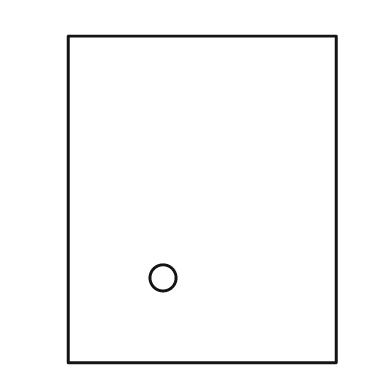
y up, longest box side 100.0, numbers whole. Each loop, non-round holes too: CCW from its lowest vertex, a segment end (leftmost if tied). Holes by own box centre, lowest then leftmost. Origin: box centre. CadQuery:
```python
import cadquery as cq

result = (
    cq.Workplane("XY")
    .moveTo(-41.0, -50.0)
    .lineTo(41.0, -50.0)
    .lineTo(41.0, 50.0)
    .lineTo(-41.0, 50.0)
    .close()
    .moveTo(-12.0, -24.0)
    .circle(4.0)
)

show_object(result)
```